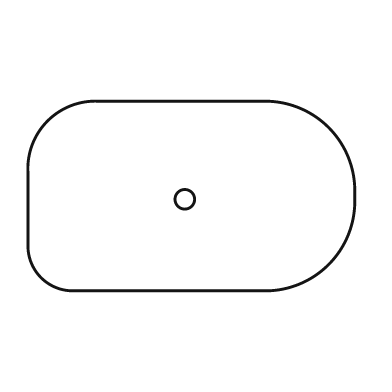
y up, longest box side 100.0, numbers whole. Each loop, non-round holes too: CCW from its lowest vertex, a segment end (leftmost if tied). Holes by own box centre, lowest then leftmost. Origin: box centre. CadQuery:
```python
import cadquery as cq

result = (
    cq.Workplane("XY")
    .moveTo(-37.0, -29.0)
    .lineTo(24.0, -29.0)
    .threePointArc((42.0, -21.0), (50.0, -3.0))
    .lineTo(50.0, 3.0)
    .threePointArc((42.0, 21.0), (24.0, 29.0))
    .lineTo(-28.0, 29.0)
    .threePointArc((-44.0, 23.0), (-50.0, 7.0))
    .lineTo(-50.0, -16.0)
    .threePointArc((-46.0, -25.0), (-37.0, -29.0))
    .close()
    .moveTo(-2.0, -1.0)
    .circle(3.0)
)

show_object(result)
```